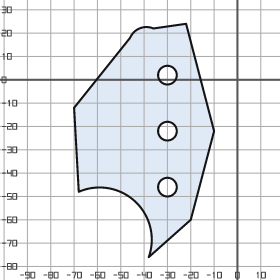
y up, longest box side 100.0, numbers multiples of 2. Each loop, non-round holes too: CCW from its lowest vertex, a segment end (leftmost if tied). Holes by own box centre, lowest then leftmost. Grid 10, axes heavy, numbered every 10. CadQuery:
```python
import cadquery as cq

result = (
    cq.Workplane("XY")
    .moveTo(-38.0, -76.0)
    .lineTo(-20.0, -60.0)
    .lineTo(-10.0, -22.0)
    .lineTo(-22.0, 24.0)
    .lineTo(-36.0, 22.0)
    .threePointArc((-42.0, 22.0), (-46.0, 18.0))
    .lineTo(-70.0, -12.0)
    .lineTo(-68.0, -48.0)
    .threePointArc((-44.0, -52.0), (-38.0, -76.0))
    .close()
    .moveTo(-30.0, -46.0)
    .circle(4.0)
    .moveTo(-30.0, -22.0)
    .circle(4.0)
    .moveTo(-30.0, 2.0)
    .circle(4.0)
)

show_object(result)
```